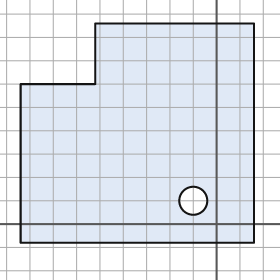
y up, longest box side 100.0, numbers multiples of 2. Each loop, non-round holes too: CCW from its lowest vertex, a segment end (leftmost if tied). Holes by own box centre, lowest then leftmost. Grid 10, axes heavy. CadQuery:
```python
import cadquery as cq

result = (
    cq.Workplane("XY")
    .moveTo(-84.0, -8.0)
    .lineTo(16.0, -8.0)
    .lineTo(16.0, 86.0)
    .lineTo(-52.0, 86.0)
    .lineTo(-52.0, 60.0)
    .lineTo(-84.0, 60.0)
    .close()
    .moveTo(-10.0, 10.0)
    .circle(6.0)
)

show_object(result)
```